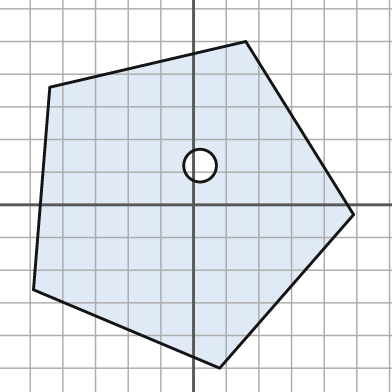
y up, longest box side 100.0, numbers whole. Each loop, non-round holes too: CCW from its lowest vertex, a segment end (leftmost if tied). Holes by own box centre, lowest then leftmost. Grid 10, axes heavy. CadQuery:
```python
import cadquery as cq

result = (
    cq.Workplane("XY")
    .moveTo(8.0, -50.0)
    .lineTo(49.0, -3.0)
    .lineTo(16.0, 50.0)
    .lineTo(-44.0, 36.0)
    .lineTo(-49.0, -26.0)
    .close()
    .moveTo(2.0, 12.0)
    .circle(5.0)
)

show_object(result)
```